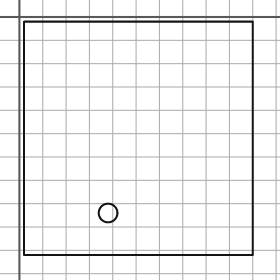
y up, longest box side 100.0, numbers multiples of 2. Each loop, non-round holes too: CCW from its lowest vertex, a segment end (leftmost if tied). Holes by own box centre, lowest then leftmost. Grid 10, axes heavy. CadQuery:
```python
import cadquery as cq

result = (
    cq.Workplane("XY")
    .moveTo(2.0, -102.0)
    .lineTo(100.0, -102.0)
    .lineTo(100.0, -2.0)
    .lineTo(2.0, -2.0)
    .close()
    .moveTo(38.0, -84.0)
    .circle(4.0)
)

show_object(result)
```